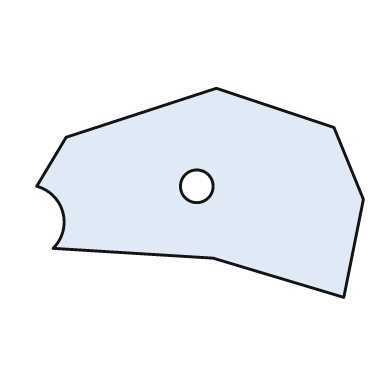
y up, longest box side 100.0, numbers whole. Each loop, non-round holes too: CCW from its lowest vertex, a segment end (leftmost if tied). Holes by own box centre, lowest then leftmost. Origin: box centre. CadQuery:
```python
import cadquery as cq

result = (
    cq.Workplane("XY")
    .moveTo(44.0, -32.0)
    .lineTo(50.0, -2.0)
    .lineTo(41.0, 20.0)
    .lineTo(5.0, 32.0)
    .lineTo(-41.0, 17.0)
    .lineTo(-50.0, 2.0)
    .threePointArc((-42.0, -6.0), (-45.0, -17.0))
    .lineTo(4.0, -20.0)
    .close()
    .moveTo(-1.0, 2.0)
    .circle(5.0)
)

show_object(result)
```